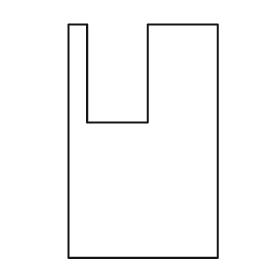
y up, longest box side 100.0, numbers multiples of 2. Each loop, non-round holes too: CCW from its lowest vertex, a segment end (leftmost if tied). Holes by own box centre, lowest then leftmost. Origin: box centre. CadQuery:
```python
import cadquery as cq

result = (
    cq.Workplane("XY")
    .moveTo(-32.0, -50.0)
    .lineTo(32.0, -50.0)
    .lineTo(32.0, 50.0)
    .lineTo(2.0, 50.0)
    .lineTo(2.0, 8.0)
    .lineTo(-24.0, 8.0)
    .lineTo(-24.0, 50.0)
    .lineTo(-32.0, 50.0)
    .close()
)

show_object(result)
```